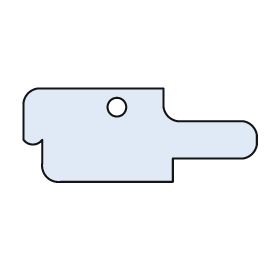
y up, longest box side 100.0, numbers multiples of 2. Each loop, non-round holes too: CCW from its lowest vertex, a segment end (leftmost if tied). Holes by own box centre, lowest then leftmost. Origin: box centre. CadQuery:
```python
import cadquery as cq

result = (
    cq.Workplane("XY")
    .moveTo(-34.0, -20.0)
    .lineTo(14.0, -20.0)
    .lineTo(14.0, -10.0)
    .lineTo(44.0, -10.0)
    .threePointArc((48.0, -8.0), (50.0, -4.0))
    .lineTo(50.0, 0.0)
    .threePointArc((48.0, 4.0), (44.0, 6.0))
    .lineTo(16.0, 6.0)
    .threePointArc((12.0, 8.0), (10.0, 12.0))
    .lineTo(10.0, 20.0)
    .lineTo(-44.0, 20.0)
    .threePointArc((-48.0, 18.0), (-50.0, 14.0))
    .lineTo(-50.0, -2.0)
    .threePointArc((-46.0, -4.0), (-42.0, -2.0))
    .lineTo(-42.0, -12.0)
    .threePointArc((-40.0, -18.0), (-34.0, -20.0))
    .close()
    .moveTo(-10.0, 12.0)
    .circle(4.0)
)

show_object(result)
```